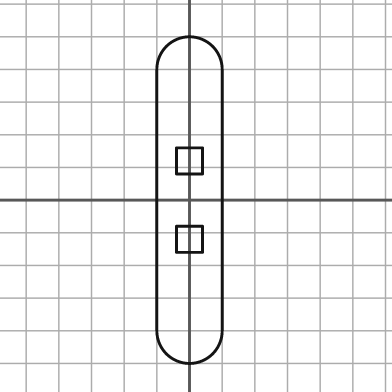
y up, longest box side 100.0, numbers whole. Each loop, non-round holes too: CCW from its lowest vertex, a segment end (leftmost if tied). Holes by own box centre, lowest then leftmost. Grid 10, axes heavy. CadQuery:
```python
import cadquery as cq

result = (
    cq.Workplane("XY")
    .moveTo(-10.0, -40.0)
    .threePointArc((0.0, -50.0), (10.0, -40.0))
    .lineTo(10.0, 40.0)
    .threePointArc((0.0, 50.0), (-10.0, 40.0))
    .close()
    .moveTo(-4.0, -16.0)
    .lineTo(4.0, -16.0)
    .lineTo(4.0, -8.0)
    .lineTo(-4.0, -8.0)
    .close()
    .moveTo(-4.0, 8.0)
    .lineTo(4.0, 8.0)
    .lineTo(4.0, 16.0)
    .lineTo(-4.0, 16.0)
    .close()
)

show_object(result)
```